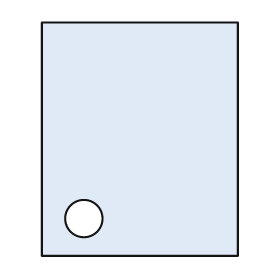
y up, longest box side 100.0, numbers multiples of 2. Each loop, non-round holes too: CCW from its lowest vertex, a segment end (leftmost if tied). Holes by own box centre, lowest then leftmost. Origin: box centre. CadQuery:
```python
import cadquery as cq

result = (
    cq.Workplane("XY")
    .moveTo(-42.0, -50.0)
    .lineTo(42.0, -50.0)
    .lineTo(42.0, 50.0)
    .lineTo(-42.0, 50.0)
    .close()
    .moveTo(-24.0, -34.0)
    .circle(8.0)
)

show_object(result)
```